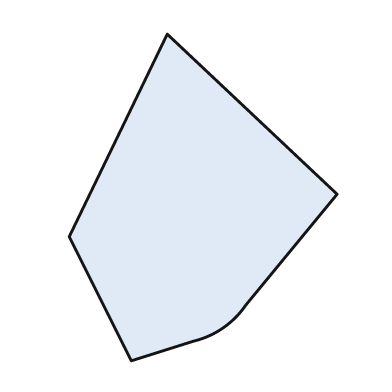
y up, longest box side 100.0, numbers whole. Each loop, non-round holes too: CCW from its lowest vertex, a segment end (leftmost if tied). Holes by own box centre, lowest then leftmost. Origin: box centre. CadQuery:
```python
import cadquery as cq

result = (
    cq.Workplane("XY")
    .moveTo(-22.0, -50.0)
    .lineTo(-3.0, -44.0)
    .threePointArc((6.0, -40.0), (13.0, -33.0))
    .lineTo(41.0, 1.0)
    .lineTo(-11.0, 50.0)
    .lineTo(-41.0, -12.0)
    .close()
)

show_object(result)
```